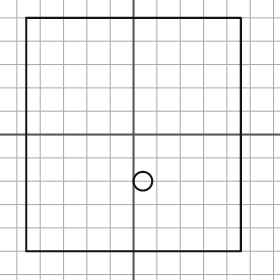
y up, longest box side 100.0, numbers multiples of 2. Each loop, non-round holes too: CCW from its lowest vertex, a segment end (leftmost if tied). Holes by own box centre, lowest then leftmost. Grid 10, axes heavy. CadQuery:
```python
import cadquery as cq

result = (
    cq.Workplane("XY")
    .moveTo(-46.0, -50.0)
    .lineTo(46.0, -50.0)
    .lineTo(46.0, 50.0)
    .lineTo(-46.0, 50.0)
    .close()
    .moveTo(4.0, -20.0)
    .circle(4.0)
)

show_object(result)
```